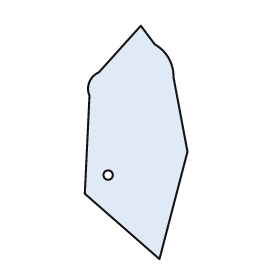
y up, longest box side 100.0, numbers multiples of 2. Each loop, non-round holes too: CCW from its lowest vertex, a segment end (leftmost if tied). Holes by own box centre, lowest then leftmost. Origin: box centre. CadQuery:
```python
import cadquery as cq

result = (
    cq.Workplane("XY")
    .moveTo(10.0, -50.0)
    .lineTo(22.0, -4.0)
    .lineTo(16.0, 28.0)
    .threePointArc((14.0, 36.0), (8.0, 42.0))
    .lineTo(2.0, 50.0)
    .lineTo(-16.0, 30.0)
    .threePointArc((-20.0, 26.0), (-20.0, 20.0))
    .lineTo(-22.0, -22.0)
    .close()
    .moveTo(-12.0, -14.0)
    .circle(2.0)
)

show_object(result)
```